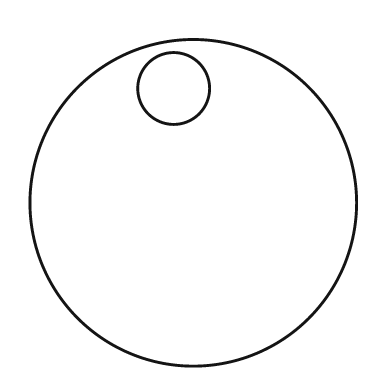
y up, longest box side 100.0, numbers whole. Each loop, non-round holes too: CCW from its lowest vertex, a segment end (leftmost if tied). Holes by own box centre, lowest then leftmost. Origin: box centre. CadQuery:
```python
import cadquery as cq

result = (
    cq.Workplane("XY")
    .moveTo(0.0, 0.0)
    .circle(50.0)
    .moveTo(-6.0, 35.0)
    .circle(11.0)
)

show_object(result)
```